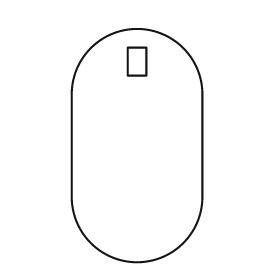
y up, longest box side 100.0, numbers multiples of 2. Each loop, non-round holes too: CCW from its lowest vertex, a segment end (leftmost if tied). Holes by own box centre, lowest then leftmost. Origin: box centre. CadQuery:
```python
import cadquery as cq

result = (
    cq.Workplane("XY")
    .moveTo(-28.0, -22.0)
    .threePointArc((0.0, -50.0), (28.0, -22.0))
    .lineTo(28.0, 22.0)
    .threePointArc((0.0, 50.0), (-28.0, 22.0))
    .close()
    .moveTo(-4.0, 30.0)
    .lineTo(4.0, 30.0)
    .lineTo(4.0, 42.0)
    .lineTo(-4.0, 42.0)
    .close()
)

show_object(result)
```